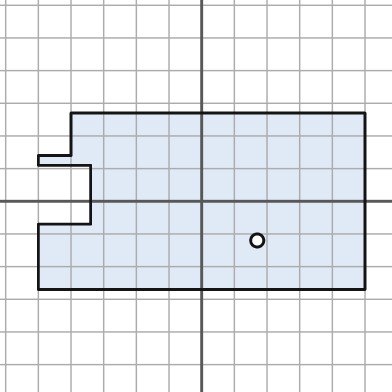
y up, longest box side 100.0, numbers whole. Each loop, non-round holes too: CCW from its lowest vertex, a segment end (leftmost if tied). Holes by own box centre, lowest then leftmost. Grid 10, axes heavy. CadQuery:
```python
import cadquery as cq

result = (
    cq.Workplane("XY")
    .moveTo(-50.0, -27.0)
    .lineTo(50.0, -27.0)
    .lineTo(50.0, 27.0)
    .lineTo(-40.0, 27.0)
    .lineTo(-40.0, 14.0)
    .lineTo(-50.0, 14.0)
    .lineTo(-50.0, 11.0)
    .lineTo(-34.0, 11.0)
    .lineTo(-34.0, -7.0)
    .lineTo(-50.0, -7.0)
    .close()
    .moveTo(17.0, -12.0)
    .circle(2.0)
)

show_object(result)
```